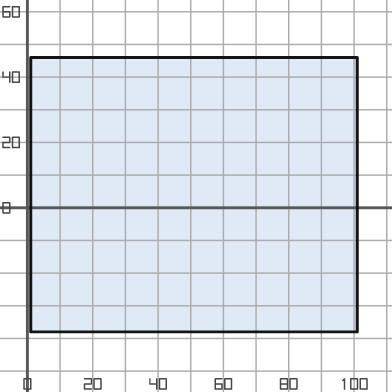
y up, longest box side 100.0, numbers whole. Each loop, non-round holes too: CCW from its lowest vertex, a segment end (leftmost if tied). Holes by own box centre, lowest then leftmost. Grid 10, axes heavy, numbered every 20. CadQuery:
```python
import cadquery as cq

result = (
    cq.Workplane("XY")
    .moveTo(1.0, -38.0)
    .lineTo(101.0, -38.0)
    .lineTo(101.0, 46.0)
    .lineTo(1.0, 46.0)
    .close()
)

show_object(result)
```